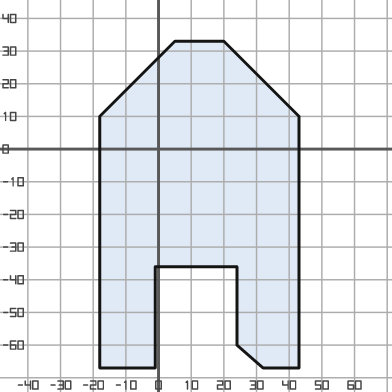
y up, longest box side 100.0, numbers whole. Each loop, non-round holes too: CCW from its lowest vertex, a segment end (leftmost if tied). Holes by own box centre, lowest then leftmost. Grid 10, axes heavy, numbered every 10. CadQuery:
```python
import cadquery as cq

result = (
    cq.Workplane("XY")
    .moveTo(-18.0, -67.0)
    .lineTo(-1.0, -67.0)
    .lineTo(-1.0, -36.0)
    .lineTo(24.0, -36.0)
    .lineTo(24.0, -60.0)
    .lineTo(32.0, -67.0)
    .lineTo(43.0, -67.0)
    .lineTo(43.0, 10.0)
    .lineTo(20.0, 33.0)
    .lineTo(5.0, 33.0)
    .lineTo(-18.0, 10.0)
    .close()
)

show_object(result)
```